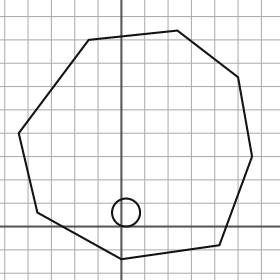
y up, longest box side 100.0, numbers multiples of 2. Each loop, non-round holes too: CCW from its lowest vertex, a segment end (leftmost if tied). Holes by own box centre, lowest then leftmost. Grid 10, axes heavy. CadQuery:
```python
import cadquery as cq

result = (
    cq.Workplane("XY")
    .moveTo(0.0, -14.0)
    .lineTo(42.0, -8.0)
    .lineTo(56.0, 30.0)
    .lineTo(50.0, 64.0)
    .lineTo(24.0, 84.0)
    .lineTo(-14.0, 80.0)
    .lineTo(-44.0, 40.0)
    .lineTo(-36.0, 6.0)
    .close()
    .moveTo(2.0, 6.0)
    .circle(6.0)
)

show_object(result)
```